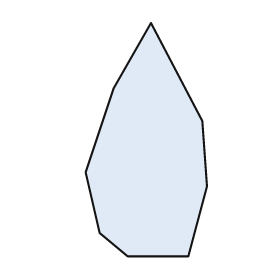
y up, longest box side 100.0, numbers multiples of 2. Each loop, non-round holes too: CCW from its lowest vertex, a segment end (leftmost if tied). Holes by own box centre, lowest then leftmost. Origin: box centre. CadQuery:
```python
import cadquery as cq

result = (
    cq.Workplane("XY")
    .moveTo(-8.0, -50.0)
    .lineTo(18.0, -50.0)
    .lineTo(26.0, -20.0)
    .lineTo(24.0, 8.0)
    .lineTo(2.0, 50.0)
    .lineTo(-14.0, 22.0)
    .lineTo(-26.0, -14.0)
    .lineTo(-20.0, -40.0)
    .close()
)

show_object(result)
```